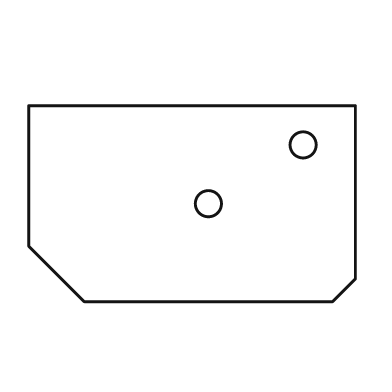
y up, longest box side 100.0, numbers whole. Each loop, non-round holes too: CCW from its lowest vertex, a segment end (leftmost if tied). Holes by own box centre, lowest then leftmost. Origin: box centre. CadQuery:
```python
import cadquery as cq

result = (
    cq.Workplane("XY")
    .moveTo(-33.0, -30.0)
    .lineTo(43.0, -30.0)
    .lineTo(50.0, -23.0)
    .lineTo(50.0, 30.0)
    .lineTo(-50.0, 30.0)
    .lineTo(-50.0, -13.0)
    .close()
    .moveTo(5.0, 0.0)
    .circle(4.0)
    .moveTo(34.0, 18.0)
    .circle(4.0)
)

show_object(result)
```